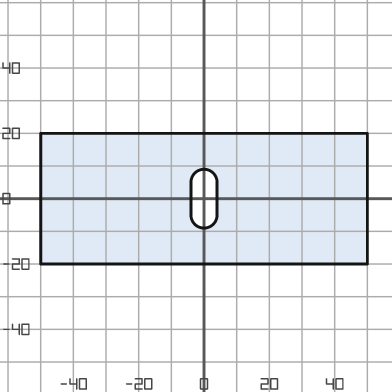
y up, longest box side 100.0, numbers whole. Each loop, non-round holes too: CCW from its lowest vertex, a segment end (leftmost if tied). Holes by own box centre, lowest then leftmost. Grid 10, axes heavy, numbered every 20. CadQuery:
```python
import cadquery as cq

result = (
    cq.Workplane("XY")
    .moveTo(-50.0, -20.0)
    .lineTo(50.0, -20.0)
    .lineTo(50.0, 20.0)
    .lineTo(-50.0, 20.0)
    .close()
    .moveTo(-4.0, -5.0)
    .threePointArc((0.0, -9.0), (4.0, -5.0))
    .lineTo(4.0, 5.0)
    .threePointArc((0.0, 9.0), (-4.0, 5.0))
    .close()
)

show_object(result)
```